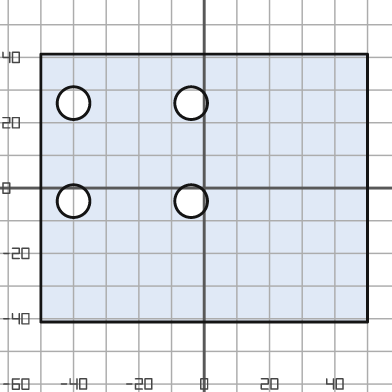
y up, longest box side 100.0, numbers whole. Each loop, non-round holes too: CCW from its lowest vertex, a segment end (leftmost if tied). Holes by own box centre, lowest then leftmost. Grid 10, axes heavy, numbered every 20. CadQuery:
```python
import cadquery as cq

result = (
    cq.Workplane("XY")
    .moveTo(-50.0, -41.0)
    .lineTo(50.0, -41.0)
    .lineTo(50.0, 41.0)
    .lineTo(-50.0, 41.0)
    .close()
    .moveTo(-40.0, -4.0)
    .circle(5.0)
    .moveTo(-4.0, -4.0)
    .circle(5.0)
    .moveTo(-40.0, 26.0)
    .circle(5.0)
    .moveTo(-4.0, 26.0)
    .circle(5.0)
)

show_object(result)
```